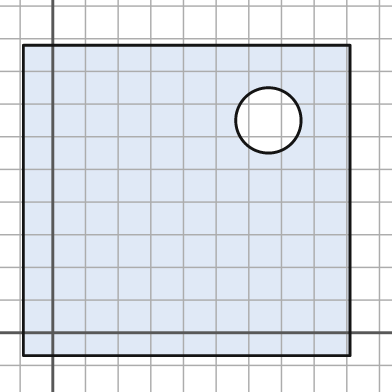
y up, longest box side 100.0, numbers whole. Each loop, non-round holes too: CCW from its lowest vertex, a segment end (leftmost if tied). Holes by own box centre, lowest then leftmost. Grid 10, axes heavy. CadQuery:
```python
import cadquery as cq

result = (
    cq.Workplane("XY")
    .moveTo(-9.0, -7.0)
    .lineTo(91.0, -7.0)
    .lineTo(91.0, 88.0)
    .lineTo(-9.0, 88.0)
    .close()
    .moveTo(66.0, 65.0)
    .circle(10.0)
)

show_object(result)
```